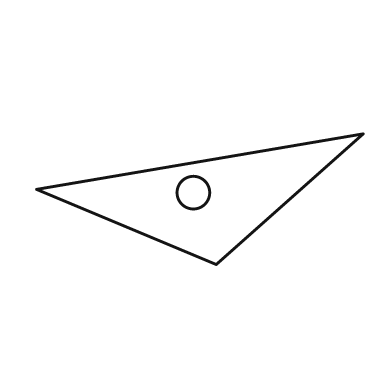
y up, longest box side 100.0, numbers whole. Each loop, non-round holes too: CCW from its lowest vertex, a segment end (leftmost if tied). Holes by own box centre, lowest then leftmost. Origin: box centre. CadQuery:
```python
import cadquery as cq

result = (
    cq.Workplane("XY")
    .moveTo(5.0, -20.0)
    .lineTo(50.0, 20.0)
    .lineTo(-50.0, 3.0)
    .close()
    .moveTo(-2.0, 2.0)
    .circle(5.0)
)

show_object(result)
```